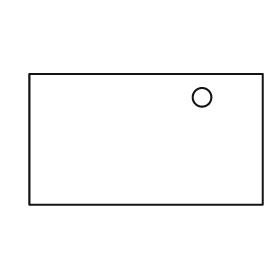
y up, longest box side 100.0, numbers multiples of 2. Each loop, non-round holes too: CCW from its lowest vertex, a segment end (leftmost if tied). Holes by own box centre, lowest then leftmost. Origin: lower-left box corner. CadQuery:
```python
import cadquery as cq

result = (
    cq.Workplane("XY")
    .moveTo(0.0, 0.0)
    .lineTo(100.0, 0.0)
    .lineTo(100.0, 56.0)
    .lineTo(0.0, 56.0)
    .close()
    .moveTo(74.0, 46.0)
    .circle(4.0)
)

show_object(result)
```